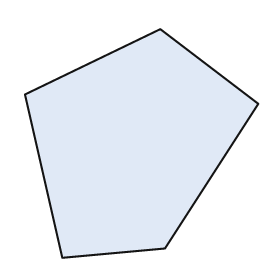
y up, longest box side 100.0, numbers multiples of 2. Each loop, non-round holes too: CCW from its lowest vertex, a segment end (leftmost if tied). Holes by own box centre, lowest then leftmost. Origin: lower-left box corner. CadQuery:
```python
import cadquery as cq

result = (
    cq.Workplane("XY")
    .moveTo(16.0, 0.0)
    .lineTo(60.0, 4.0)
    .lineTo(100.0, 66.0)
    .lineTo(58.0, 98.0)
    .lineTo(0.0, 70.0)
    .close()
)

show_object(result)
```